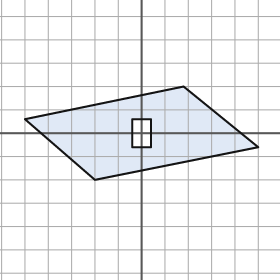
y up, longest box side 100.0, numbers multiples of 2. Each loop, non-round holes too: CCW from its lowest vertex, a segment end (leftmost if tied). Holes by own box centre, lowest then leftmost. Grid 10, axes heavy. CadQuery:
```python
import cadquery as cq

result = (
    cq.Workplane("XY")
    .moveTo(-20.0, -20.0)
    .lineTo(50.0, -6.0)
    .lineTo(18.0, 20.0)
    .lineTo(-50.0, 6.0)
    .close()
    .moveTo(-4.0, -6.0)
    .lineTo(4.0, -6.0)
    .lineTo(4.0, 6.0)
    .lineTo(-4.0, 6.0)
    .close()
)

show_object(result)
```